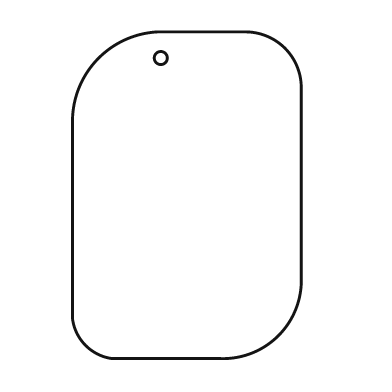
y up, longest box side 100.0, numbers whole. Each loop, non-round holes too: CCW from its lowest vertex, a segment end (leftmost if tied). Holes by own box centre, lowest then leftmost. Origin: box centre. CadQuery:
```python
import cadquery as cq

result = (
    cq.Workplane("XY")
    .moveTo(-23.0, -50.0)
    .lineTo(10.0, -50.0)
    .threePointArc((28.0, -43.0), (35.0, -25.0))
    .lineTo(35.0, 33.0)
    .threePointArc((30.0, 45.0), (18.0, 50.0))
    .lineTo(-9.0, 50.0)
    .threePointArc((-27.0, 42.0), (-35.0, 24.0))
    .lineTo(-35.0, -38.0)
    .threePointArc((-31.0, -46.0), (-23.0, -50.0))
    .close()
    .moveTo(-8.0, 42.0)
    .circle(2.0)
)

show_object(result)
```